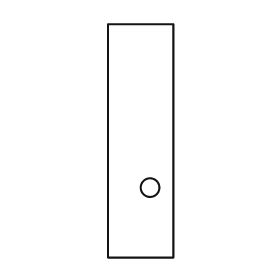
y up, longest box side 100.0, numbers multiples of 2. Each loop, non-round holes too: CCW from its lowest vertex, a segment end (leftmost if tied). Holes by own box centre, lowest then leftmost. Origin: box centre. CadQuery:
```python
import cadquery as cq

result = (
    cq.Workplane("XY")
    .moveTo(-14.0, -50.0)
    .lineTo(14.0, -50.0)
    .lineTo(14.0, 50.0)
    .lineTo(-14.0, 50.0)
    .close()
    .moveTo(4.0, -20.0)
    .circle(4.0)
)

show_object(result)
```